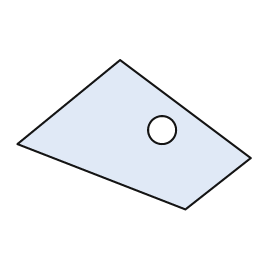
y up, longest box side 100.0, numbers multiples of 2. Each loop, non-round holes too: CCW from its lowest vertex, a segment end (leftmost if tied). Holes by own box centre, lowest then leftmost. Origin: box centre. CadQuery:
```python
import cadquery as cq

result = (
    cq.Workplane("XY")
    .moveTo(22.0, -32.0)
    .lineTo(50.0, -10.0)
    .lineTo(-6.0, 32.0)
    .lineTo(-50.0, -4.0)
    .close()
    .moveTo(12.0, 2.0)
    .circle(6.0)
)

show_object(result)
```